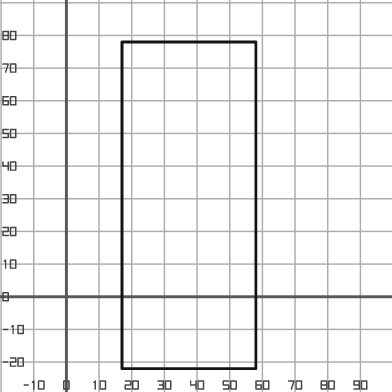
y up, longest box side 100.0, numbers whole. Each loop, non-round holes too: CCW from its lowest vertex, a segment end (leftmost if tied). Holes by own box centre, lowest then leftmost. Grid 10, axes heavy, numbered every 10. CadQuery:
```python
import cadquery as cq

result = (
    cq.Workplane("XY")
    .moveTo(17.0, -22.0)
    .lineTo(58.0, -22.0)
    .lineTo(58.0, 78.0)
    .lineTo(17.0, 78.0)
    .close()
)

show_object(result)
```